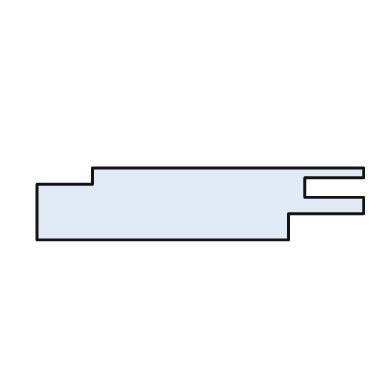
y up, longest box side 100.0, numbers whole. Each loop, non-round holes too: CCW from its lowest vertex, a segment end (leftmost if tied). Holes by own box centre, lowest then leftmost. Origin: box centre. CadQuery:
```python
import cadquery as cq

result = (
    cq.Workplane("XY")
    .moveTo(-50.0, -11.0)
    .lineTo(27.0, -11.0)
    .lineTo(27.0, -3.0)
    .lineTo(50.0, -3.0)
    .lineTo(50.0, 2.0)
    .lineTo(32.0, 2.0)
    .lineTo(32.0, 8.0)
    .lineTo(50.0, 8.0)
    .lineTo(50.0, 11.0)
    .lineTo(-33.0, 11.0)
    .lineTo(-33.0, 6.0)
    .lineTo(-50.0, 6.0)
    .close()
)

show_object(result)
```